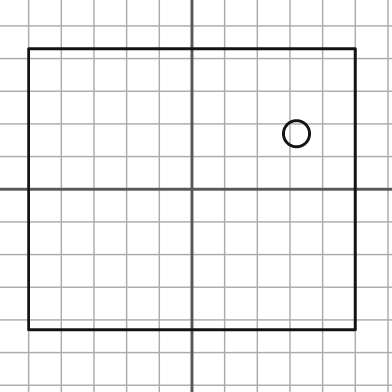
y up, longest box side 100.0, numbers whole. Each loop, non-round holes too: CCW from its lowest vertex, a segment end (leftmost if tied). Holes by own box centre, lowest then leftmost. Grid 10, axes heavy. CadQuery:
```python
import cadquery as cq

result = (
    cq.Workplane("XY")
    .moveTo(-50.0, -43.0)
    .lineTo(50.0, -43.0)
    .lineTo(50.0, 43.0)
    .lineTo(-50.0, 43.0)
    .close()
    .moveTo(32.0, 17.0)
    .circle(4.0)
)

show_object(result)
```